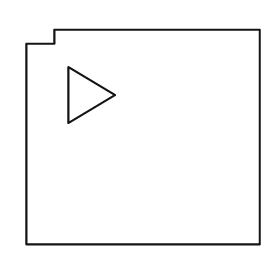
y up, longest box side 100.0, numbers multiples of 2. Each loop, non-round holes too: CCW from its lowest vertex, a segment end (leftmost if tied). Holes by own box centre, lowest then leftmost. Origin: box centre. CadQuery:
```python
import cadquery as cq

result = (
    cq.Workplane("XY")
    .moveTo(-50.0, -46.0)
    .lineTo(50.0, -46.0)
    .lineTo(50.0, 46.0)
    .lineTo(-38.0, 46.0)
    .lineTo(-38.0, 40.0)
    .lineTo(-50.0, 40.0)
    .close()
    .moveTo(-32.0, 6.0)
    .lineTo(-12.0, 18.0)
    .lineTo(-32.0, 30.0)
    .close()
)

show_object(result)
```